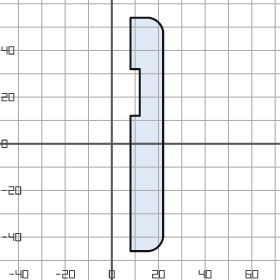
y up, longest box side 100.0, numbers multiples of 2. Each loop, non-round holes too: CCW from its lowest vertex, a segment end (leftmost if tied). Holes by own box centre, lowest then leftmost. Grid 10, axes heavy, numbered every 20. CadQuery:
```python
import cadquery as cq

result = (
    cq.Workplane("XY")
    .moveTo(8.0, -46.0)
    .lineTo(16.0, -46.0)
    .threePointArc((20.0, -44.0), (22.0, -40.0))
    .lineTo(22.0, 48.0)
    .threePointArc((20.0, 52.0), (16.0, 54.0))
    .lineTo(8.0, 54.0)
    .lineTo(8.0, 32.0)
    .lineTo(12.0, 32.0)
    .lineTo(12.0, 12.0)
    .lineTo(8.0, 12.0)
    .close()
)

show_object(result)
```